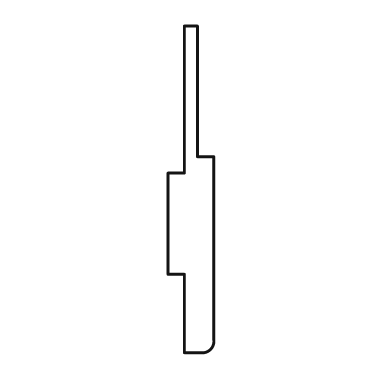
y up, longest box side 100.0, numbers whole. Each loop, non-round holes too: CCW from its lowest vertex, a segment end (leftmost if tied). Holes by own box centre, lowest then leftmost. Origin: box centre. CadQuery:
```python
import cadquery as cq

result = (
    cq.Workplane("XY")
    .moveTo(-2.0, -50.0)
    .lineTo(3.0, -50.0)
    .threePointArc((6.0, -49.0), (7.0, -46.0))
    .lineTo(7.0, 10.0)
    .lineTo(2.0, 10.0)
    .lineTo(2.0, 50.0)
    .lineTo(-2.0, 50.0)
    .lineTo(-2.0, 5.0)
    .lineTo(-7.0, 5.0)
    .lineTo(-7.0, -26.0)
    .lineTo(-2.0, -26.0)
    .close()
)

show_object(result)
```